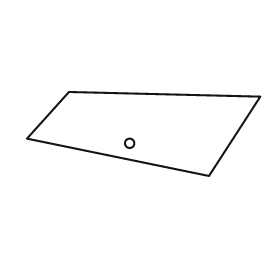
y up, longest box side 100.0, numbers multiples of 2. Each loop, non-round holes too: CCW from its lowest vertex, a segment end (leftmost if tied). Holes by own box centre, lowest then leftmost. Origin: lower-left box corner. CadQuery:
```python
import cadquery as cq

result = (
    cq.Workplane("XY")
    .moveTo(78.0, 0.0)
    .lineTo(100.0, 34.0)
    .lineTo(18.0, 36.0)
    .lineTo(0.0, 16.0)
    .close()
    .moveTo(44.0, 14.0)
    .circle(2.0)
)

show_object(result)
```